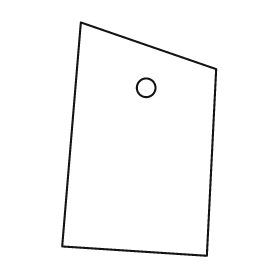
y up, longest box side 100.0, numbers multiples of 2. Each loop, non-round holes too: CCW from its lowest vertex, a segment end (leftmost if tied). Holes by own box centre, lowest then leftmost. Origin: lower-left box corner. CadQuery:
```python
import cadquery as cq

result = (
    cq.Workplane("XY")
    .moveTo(62.0, 0.0)
    .lineTo(66.0, 80.0)
    .lineTo(8.0, 100.0)
    .lineTo(0.0, 4.0)
    .close()
    .moveTo(36.0, 72.0)
    .circle(4.0)
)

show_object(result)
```